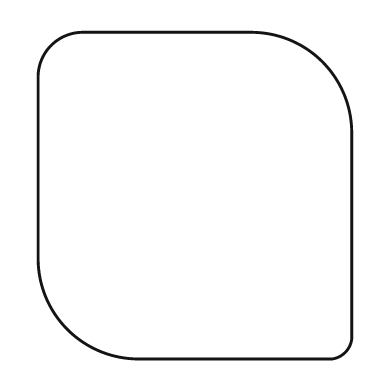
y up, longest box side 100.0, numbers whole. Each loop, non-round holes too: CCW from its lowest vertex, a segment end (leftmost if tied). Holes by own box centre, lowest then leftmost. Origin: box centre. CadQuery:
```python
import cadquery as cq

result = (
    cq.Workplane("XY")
    .moveTo(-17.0, -50.0)
    .lineTo(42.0, -50.0)
    .threePointArc((46.0, -48.0), (48.0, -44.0))
    .lineTo(48.0, 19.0)
    .threePointArc((39.0, 41.0), (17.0, 50.0))
    .lineTo(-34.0, 50.0)
    .threePointArc((-44.0, 46.0), (-48.0, 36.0))
    .lineTo(-48.0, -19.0)
    .threePointArc((-39.0, -41.0), (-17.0, -50.0))
    .close()
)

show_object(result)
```